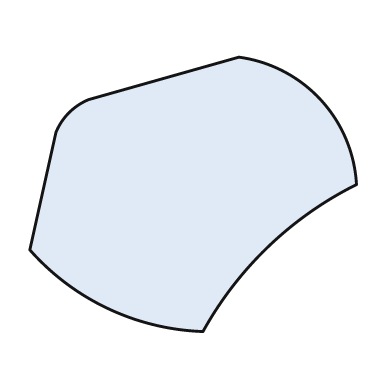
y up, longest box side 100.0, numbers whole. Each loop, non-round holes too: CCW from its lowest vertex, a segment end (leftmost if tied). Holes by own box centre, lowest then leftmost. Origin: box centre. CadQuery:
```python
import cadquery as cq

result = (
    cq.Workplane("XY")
    .moveTo(3.0, -42.0)
    .threePointArc((23.0, -16.0), (50.0, 3.0))
    .threePointArc((39.0, 29.0), (14.0, 42.0))
    .lineTo(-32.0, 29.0)
    .threePointArc((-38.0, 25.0), (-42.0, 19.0))
    .lineTo(-50.0, -17.0)
    .threePointArc((-26.0, -35.0), (3.0, -42.0))
    .close()
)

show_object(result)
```